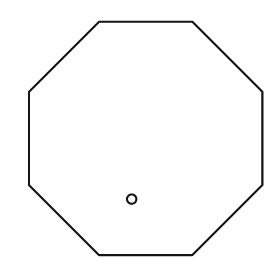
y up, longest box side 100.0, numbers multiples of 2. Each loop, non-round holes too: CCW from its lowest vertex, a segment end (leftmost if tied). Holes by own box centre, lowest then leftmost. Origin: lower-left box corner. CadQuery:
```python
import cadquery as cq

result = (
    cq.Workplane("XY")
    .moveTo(30.0, 0.0)
    .lineTo(70.0, 0.0)
    .lineTo(100.0, 30.0)
    .lineTo(100.0, 70.0)
    .lineTo(70.0, 100.0)
    .lineTo(30.0, 100.0)
    .lineTo(0.0, 70.0)
    .lineTo(0.0, 30.0)
    .close()
    .moveTo(44.0, 24.0)
    .circle(2.0)
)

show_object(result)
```